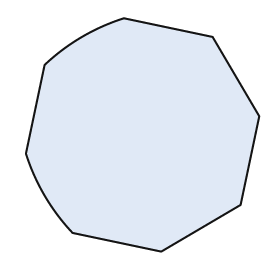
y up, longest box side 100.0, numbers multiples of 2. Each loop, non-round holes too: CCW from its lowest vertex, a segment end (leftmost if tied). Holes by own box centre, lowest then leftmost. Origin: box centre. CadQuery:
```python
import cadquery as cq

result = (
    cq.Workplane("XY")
    .moveTo(8.0, -50.0)
    .lineTo(42.0, -30.0)
    .lineTo(50.0, 8.0)
    .lineTo(30.0, 42.0)
    .lineTo(-8.0, 50.0)
    .threePointArc((-26.0, 42.0), (-42.0, 30.0))
    .lineTo(-50.0, -8.0)
    .threePointArc((-42.0, -26.0), (-30.0, -42.0))
    .close()
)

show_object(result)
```